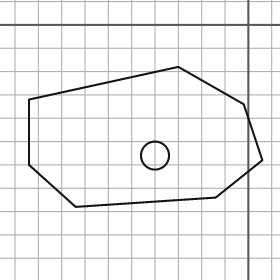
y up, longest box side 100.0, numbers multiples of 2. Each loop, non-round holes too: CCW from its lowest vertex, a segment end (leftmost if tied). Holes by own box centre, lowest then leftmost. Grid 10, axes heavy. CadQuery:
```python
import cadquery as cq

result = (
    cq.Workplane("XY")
    .moveTo(-74.0, -78.0)
    .lineTo(-14.0, -74.0)
    .lineTo(6.0, -58.0)
    .lineTo(-2.0, -34.0)
    .lineTo(-30.0, -18.0)
    .lineTo(-94.0, -32.0)
    .lineTo(-94.0, -60.0)
    .close()
    .moveTo(-40.0, -56.0)
    .circle(6.0)
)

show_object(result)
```